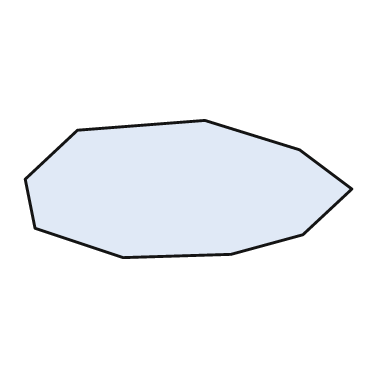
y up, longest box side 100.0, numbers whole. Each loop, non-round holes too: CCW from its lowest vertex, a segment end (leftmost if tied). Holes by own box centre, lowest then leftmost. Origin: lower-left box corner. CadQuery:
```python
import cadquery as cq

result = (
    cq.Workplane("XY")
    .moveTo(30.0, 0.0)
    .lineTo(63.0, 1.0)
    .lineTo(85.0, 7.0)
    .lineTo(100.0, 21.0)
    .lineTo(84.0, 33.0)
    .lineTo(55.0, 42.0)
    .lineTo(16.0, 39.0)
    .lineTo(0.0, 24.0)
    .lineTo(3.0, 9.0)
    .close()
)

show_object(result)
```